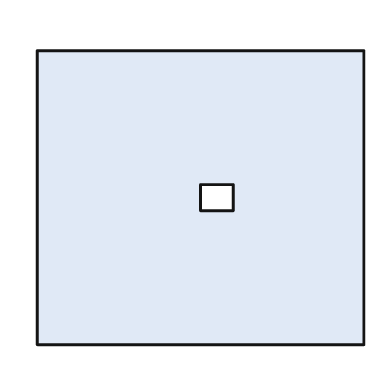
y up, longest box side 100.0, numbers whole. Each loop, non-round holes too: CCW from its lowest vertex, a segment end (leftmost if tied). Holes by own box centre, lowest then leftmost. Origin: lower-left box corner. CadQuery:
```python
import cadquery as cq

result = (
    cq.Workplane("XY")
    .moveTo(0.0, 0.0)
    .lineTo(100.0, 0.0)
    .lineTo(100.0, 90.0)
    .lineTo(0.0, 90.0)
    .close()
    .moveTo(50.0, 41.0)
    .lineTo(60.0, 41.0)
    .lineTo(60.0, 49.0)
    .lineTo(50.0, 49.0)
    .close()
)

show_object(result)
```